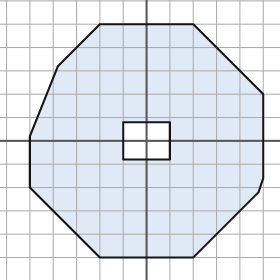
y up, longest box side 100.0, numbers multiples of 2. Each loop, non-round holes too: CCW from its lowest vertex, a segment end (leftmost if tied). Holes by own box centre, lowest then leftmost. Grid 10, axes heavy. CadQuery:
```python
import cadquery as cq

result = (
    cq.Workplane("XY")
    .moveTo(-20.0, -50.0)
    .lineTo(20.0, -50.0)
    .lineTo(48.0, -22.0)
    .lineTo(50.0, -16.0)
    .lineTo(50.0, 20.0)
    .lineTo(20.0, 50.0)
    .lineTo(-20.0, 50.0)
    .lineTo(-38.0, 32.0)
    .lineTo(-50.0, 2.0)
    .lineTo(-50.0, -20.0)
    .close()
    .moveTo(-10.0, -8.0)
    .lineTo(10.0, -8.0)
    .lineTo(10.0, 8.0)
    .lineTo(-10.0, 8.0)
    .close()
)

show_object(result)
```